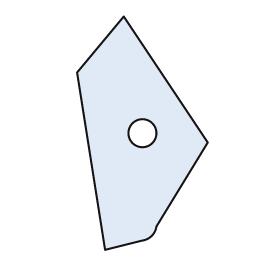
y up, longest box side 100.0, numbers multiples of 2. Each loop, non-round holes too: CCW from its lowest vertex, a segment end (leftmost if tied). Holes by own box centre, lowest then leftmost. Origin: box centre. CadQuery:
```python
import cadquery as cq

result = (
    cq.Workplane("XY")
    .moveTo(-16.0, -50.0)
    .lineTo(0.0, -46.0)
    .threePointArc((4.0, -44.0), (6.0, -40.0))
    .lineTo(28.0, -4.0)
    .lineTo(-8.0, 50.0)
    .lineTo(-28.0, 26.0)
    .close()
    .moveTo(0.0, 0.0)
    .circle(6.0)
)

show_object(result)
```